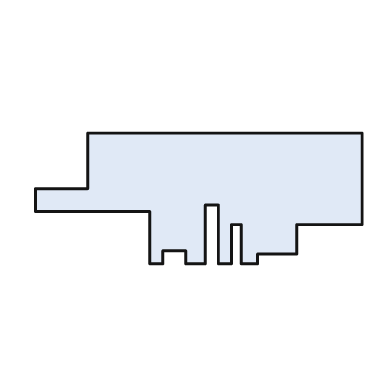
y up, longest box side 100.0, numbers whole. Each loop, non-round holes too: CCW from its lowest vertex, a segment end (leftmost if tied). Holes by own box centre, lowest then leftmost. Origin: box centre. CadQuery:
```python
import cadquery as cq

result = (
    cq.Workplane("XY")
    .moveTo(-15.0, -20.0)
    .lineTo(-11.0, -20.0)
    .lineTo(-11.0, -16.0)
    .lineTo(-4.0, -16.0)
    .lineTo(-4.0, -20.0)
    .lineTo(2.0, -20.0)
    .lineTo(2.0, -2.0)
    .lineTo(6.0, -2.0)
    .lineTo(6.0, -20.0)
    .lineTo(10.0, -20.0)
    .lineTo(10.0, -8.0)
    .lineTo(13.0, -8.0)
    .lineTo(13.0, -20.0)
    .lineTo(18.0, -20.0)
    .lineTo(18.0, -17.0)
    .lineTo(30.0, -17.0)
    .lineTo(30.0, -8.0)
    .lineTo(50.0, -8.0)
    .lineTo(50.0, 20.0)
    .lineTo(-34.0, 20.0)
    .lineTo(-34.0, 3.0)
    .lineTo(-50.0, 3.0)
    .lineTo(-50.0, -4.0)
    .lineTo(-15.0, -4.0)
    .close()
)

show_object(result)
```